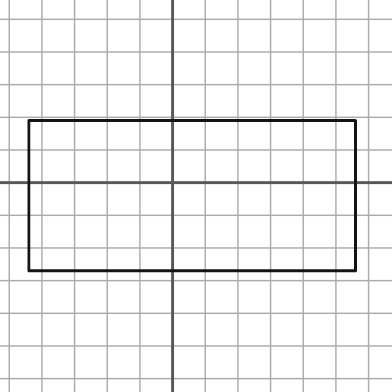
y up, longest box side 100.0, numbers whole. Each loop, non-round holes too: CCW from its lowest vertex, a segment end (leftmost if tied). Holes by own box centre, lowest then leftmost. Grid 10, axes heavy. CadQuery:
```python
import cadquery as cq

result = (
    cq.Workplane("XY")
    .moveTo(-44.0, -27.0)
    .lineTo(56.0, -27.0)
    .lineTo(56.0, 19.0)
    .lineTo(-44.0, 19.0)
    .close()
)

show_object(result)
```